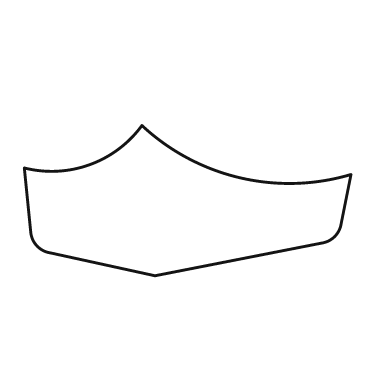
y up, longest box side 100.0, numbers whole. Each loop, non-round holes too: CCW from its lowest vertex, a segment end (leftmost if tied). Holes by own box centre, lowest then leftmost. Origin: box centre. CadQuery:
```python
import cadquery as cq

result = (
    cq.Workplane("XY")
    .moveTo(-10.0, -23.0)
    .lineTo(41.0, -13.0)
    .threePointArc((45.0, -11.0), (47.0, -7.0))
    .lineTo(50.0, 8.0)
    .threePointArc((16.0, 7.0), (-14.0, 23.0))
    .threePointArc((-30.0, 11.0), (-50.0, 10.0))
    .lineTo(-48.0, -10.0)
    .threePointArc((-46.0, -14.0), (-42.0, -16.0))
    .close()
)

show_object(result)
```